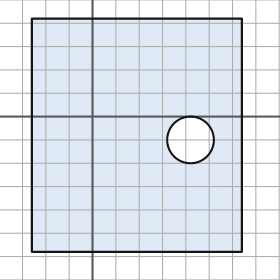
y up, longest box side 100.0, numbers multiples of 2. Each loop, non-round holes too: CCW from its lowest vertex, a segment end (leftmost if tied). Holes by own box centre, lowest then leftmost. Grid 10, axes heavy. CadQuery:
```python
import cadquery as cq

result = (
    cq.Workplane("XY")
    .moveTo(-26.0, -58.0)
    .lineTo(64.0, -58.0)
    .lineTo(64.0, 42.0)
    .lineTo(-26.0, 42.0)
    .close()
    .moveTo(42.0, -10.0)
    .circle(10.0)
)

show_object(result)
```